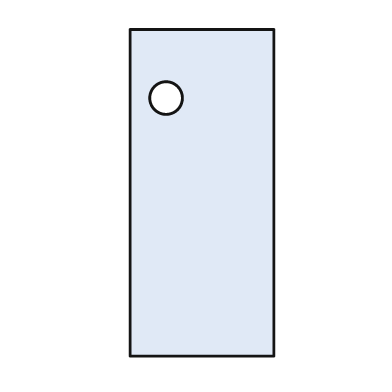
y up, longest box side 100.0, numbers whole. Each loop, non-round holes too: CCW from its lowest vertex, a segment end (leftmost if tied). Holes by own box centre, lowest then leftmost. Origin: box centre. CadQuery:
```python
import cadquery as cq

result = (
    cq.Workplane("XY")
    .moveTo(-22.0, -50.0)
    .lineTo(22.0, -50.0)
    .lineTo(22.0, 50.0)
    .lineTo(-22.0, 50.0)
    .close()
    .moveTo(-11.0, 29.0)
    .circle(5.0)
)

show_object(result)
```